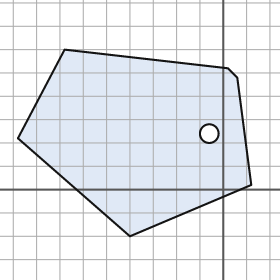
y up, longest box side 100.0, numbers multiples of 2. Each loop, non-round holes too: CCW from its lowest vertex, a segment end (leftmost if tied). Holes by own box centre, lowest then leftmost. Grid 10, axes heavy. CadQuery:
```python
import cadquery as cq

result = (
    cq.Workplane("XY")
    .moveTo(-40.0, -20.0)
    .lineTo(12.0, 2.0)
    .lineTo(6.0, 48.0)
    .lineTo(2.0, 52.0)
    .lineTo(-68.0, 60.0)
    .lineTo(-88.0, 22.0)
    .close()
    .moveTo(-6.0, 24.0)
    .circle(4.0)
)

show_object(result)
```